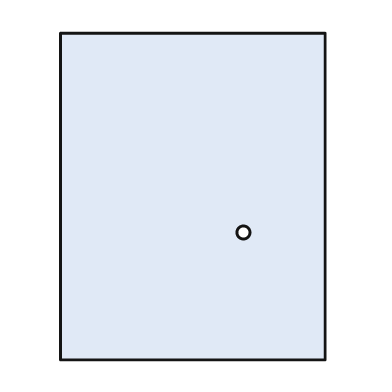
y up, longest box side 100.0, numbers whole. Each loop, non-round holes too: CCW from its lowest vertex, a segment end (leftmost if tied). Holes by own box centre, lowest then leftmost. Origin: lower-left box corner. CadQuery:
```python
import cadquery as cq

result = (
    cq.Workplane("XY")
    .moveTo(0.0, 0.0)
    .lineTo(81.0, 0.0)
    .lineTo(81.0, 100.0)
    .lineTo(0.0, 100.0)
    .close()
    .moveTo(56.0, 39.0)
    .circle(2.0)
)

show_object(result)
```